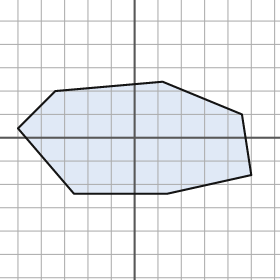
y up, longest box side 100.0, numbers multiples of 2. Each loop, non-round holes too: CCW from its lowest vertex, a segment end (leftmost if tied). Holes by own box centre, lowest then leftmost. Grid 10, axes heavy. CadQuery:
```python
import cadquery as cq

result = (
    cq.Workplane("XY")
    .moveTo(-26.0, -24.0)
    .lineTo(14.0, -24.0)
    .lineTo(50.0, -16.0)
    .lineTo(46.0, 10.0)
    .lineTo(12.0, 24.0)
    .lineTo(-34.0, 20.0)
    .lineTo(-50.0, 4.0)
    .close()
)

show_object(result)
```